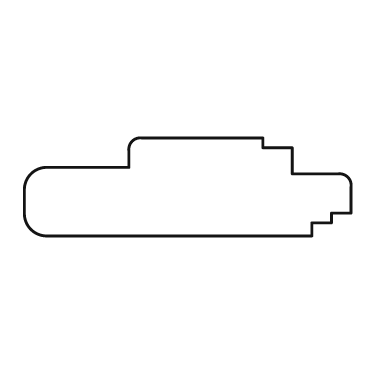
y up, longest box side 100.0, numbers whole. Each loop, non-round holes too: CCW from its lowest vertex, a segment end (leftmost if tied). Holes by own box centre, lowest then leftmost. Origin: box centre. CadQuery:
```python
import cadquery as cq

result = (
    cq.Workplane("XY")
    .moveTo(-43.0, -15.0)
    .lineTo(38.0, -15.0)
    .lineTo(38.0, -11.0)
    .lineTo(44.0, -11.0)
    .lineTo(44.0, -8.0)
    .lineTo(50.0, -8.0)
    .lineTo(50.0, 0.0)
    .threePointArc((49.0, 3.0), (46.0, 4.0))
    .lineTo(32.0, 4.0)
    .lineTo(32.0, 12.0)
    .lineTo(23.0, 12.0)
    .lineTo(23.0, 15.0)
    .lineTo(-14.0, 15.0)
    .threePointArc((-17.0, 14.0), (-18.0, 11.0))
    .lineTo(-18.0, 6.0)
    .lineTo(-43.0, 6.0)
    .threePointArc((-48.0, 4.0), (-50.0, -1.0))
    .lineTo(-50.0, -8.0)
    .threePointArc((-48.0, -13.0), (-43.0, -15.0))
    .close()
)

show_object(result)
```